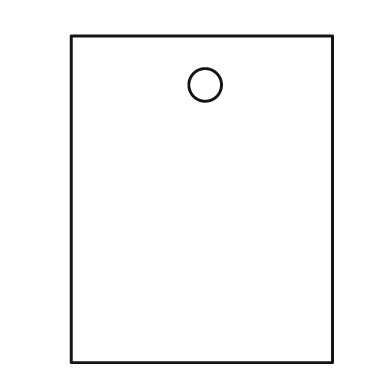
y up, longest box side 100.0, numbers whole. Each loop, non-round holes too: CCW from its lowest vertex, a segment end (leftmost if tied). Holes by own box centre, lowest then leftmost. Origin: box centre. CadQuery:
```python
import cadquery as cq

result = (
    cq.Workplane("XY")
    .moveTo(-40.0, -50.0)
    .lineTo(40.0, -50.0)
    .lineTo(40.0, 50.0)
    .lineTo(-40.0, 50.0)
    .close()
    .moveTo(1.0, 35.0)
    .circle(5.0)
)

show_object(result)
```